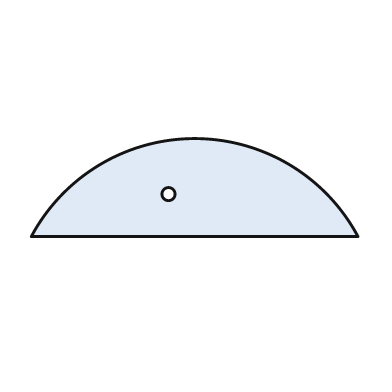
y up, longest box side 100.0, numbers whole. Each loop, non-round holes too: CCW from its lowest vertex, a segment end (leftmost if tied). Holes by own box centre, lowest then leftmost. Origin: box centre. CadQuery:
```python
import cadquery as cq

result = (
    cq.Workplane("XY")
    .moveTo(-50.0, -15.0)
    .lineTo(50.0, -15.0)
    .threePointArc((0.0, 15.0), (-50.0, -15.0))
    .close()
    .moveTo(-8.0, -2.0)
    .circle(2.0)
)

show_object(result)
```